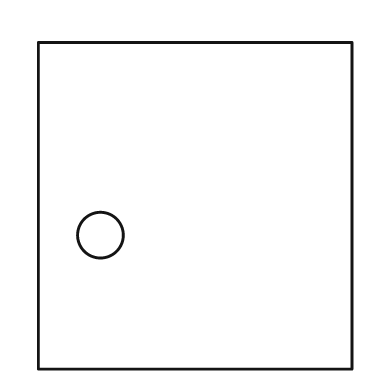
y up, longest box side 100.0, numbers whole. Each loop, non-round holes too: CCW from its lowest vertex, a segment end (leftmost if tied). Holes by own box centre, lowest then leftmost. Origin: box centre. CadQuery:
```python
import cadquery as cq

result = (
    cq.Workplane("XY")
    .moveTo(-48.0, -50.0)
    .lineTo(48.0, -50.0)
    .lineTo(48.0, 50.0)
    .lineTo(-48.0, 50.0)
    .close()
    .moveTo(-29.0, -9.0)
    .circle(7.0)
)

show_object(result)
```